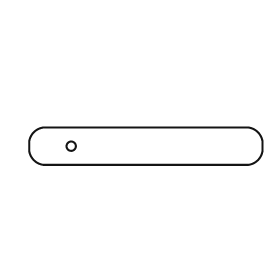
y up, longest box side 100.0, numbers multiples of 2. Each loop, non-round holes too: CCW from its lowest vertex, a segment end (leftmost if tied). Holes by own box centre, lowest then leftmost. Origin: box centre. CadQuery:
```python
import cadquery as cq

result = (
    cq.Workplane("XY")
    .moveTo(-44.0, -8.0)
    .lineTo(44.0, -8.0)
    .threePointArc((48.0, -6.0), (50.0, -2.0))
    .lineTo(50.0, 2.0)
    .threePointArc((48.0, 6.0), (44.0, 8.0))
    .lineTo(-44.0, 8.0)
    .threePointArc((-48.0, 6.0), (-50.0, 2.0))
    .lineTo(-50.0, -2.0)
    .threePointArc((-48.0, -6.0), (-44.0, -8.0))
    .close()
    .moveTo(-32.0, 0.0)
    .circle(2.0)
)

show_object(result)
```